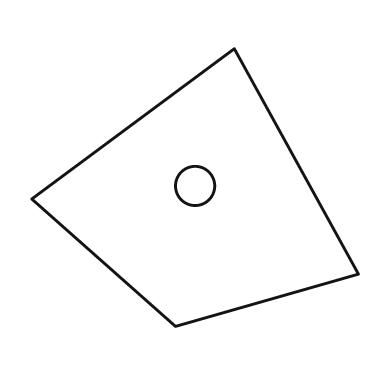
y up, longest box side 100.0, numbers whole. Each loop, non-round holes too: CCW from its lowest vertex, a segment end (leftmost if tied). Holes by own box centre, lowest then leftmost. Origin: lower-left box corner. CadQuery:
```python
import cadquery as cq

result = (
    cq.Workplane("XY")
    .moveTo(44.0, 0.0)
    .lineTo(100.0, 16.0)
    .lineTo(62.0, 85.0)
    .lineTo(0.0, 39.0)
    .close()
    .moveTo(50.0, 43.0)
    .circle(6.0)
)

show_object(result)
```